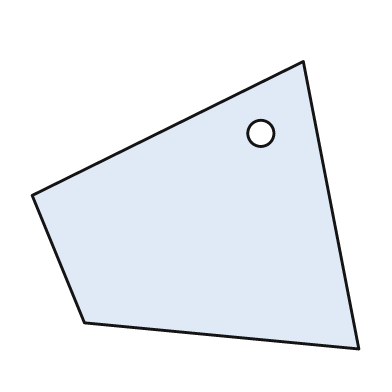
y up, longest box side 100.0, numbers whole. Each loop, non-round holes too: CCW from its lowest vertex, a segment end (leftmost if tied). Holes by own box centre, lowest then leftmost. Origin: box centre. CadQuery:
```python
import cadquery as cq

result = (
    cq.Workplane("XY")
    .moveTo(50.0, -44.0)
    .lineTo(33.0, 44.0)
    .lineTo(-50.0, 3.0)
    .lineTo(-34.0, -36.0)
    .close()
    .moveTo(20.0, 22.0)
    .circle(4.0)
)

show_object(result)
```